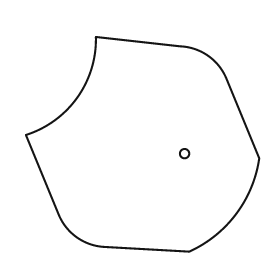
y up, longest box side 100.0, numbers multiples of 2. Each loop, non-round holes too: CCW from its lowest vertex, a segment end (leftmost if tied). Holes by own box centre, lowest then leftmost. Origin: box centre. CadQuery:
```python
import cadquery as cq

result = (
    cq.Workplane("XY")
    .moveTo(20.0, -46.0)
    .threePointArc((40.0, -30.0), (50.0, -6.0))
    .lineTo(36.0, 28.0)
    .threePointArc((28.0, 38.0), (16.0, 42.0))
    .lineTo(-20.0, 46.0)
    .threePointArc((-28.0, 20.0), (-50.0, 4.0))
    .lineTo(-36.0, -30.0)
    .threePointArc((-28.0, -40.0), (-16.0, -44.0))
    .close()
    .moveTo(18.0, -4.0)
    .circle(2.0)
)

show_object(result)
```